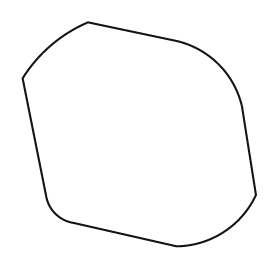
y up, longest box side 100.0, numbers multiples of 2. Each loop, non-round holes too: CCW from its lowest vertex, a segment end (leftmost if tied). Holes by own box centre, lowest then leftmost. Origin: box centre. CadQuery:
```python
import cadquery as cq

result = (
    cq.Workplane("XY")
    .moveTo(16.0, -48.0)
    .threePointArc((36.0, -42.0), (50.0, -26.0))
    .lineTo(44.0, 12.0)
    .threePointArc((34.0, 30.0), (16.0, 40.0))
    .lineTo(-22.0, 48.0)
    .threePointArc((-38.0, 38.0), (-50.0, 24.0))
    .lineTo(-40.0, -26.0)
    .threePointArc((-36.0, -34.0), (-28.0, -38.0))
    .close()
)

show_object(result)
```